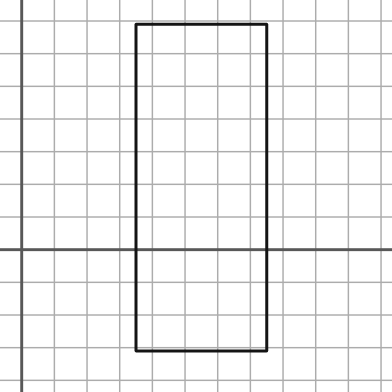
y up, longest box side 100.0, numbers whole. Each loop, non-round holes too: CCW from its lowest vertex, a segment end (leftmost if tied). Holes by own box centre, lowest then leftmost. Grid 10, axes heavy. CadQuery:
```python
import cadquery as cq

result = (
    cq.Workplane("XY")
    .moveTo(35.0, -31.0)
    .lineTo(75.0, -31.0)
    .lineTo(75.0, 69.0)
    .lineTo(35.0, 69.0)
    .close()
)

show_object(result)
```